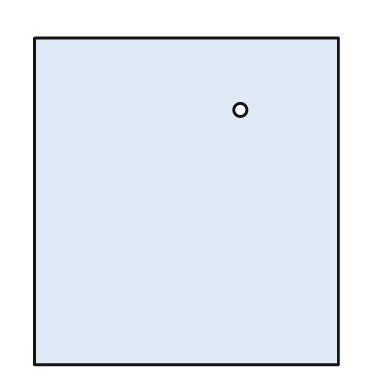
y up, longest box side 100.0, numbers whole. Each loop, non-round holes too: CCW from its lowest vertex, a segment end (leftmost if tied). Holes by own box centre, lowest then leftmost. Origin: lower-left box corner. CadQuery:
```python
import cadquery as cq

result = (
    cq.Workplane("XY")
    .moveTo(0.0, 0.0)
    .lineTo(93.0, 0.0)
    .lineTo(93.0, 100.0)
    .lineTo(0.0, 100.0)
    .close()
    .moveTo(63.0, 78.0)
    .circle(2.0)
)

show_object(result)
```